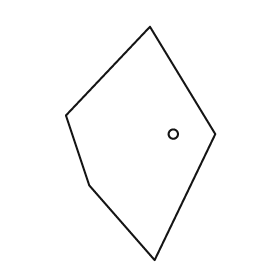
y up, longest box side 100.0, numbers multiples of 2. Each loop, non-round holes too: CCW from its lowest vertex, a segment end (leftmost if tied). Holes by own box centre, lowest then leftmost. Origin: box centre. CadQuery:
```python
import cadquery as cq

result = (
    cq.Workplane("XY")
    .moveTo(6.0, -50.0)
    .lineTo(32.0, 4.0)
    .lineTo(4.0, 50.0)
    .lineTo(-32.0, 12.0)
    .lineTo(-22.0, -18.0)
    .close()
    .moveTo(14.0, 4.0)
    .circle(2.0)
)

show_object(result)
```